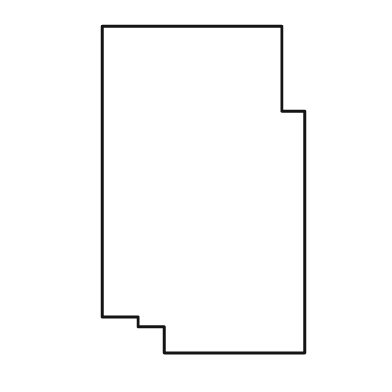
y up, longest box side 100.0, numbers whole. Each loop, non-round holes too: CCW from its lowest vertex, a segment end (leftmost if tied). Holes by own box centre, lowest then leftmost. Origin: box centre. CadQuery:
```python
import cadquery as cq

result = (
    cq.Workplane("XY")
    .moveTo(-12.0, -50.0)
    .lineTo(31.0, -50.0)
    .lineTo(31.0, 24.0)
    .lineTo(24.0, 24.0)
    .lineTo(24.0, 50.0)
    .lineTo(-31.0, 50.0)
    .lineTo(-31.0, -39.0)
    .lineTo(-20.0, -39.0)
    .lineTo(-20.0, -42.0)
    .lineTo(-12.0, -42.0)
    .close()
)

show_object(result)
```